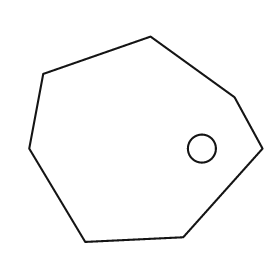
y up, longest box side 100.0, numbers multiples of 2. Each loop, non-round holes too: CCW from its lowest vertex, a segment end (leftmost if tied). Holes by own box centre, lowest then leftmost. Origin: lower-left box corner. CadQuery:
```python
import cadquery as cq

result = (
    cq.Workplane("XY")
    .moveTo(24.0, 0.0)
    .lineTo(66.0, 2.0)
    .lineTo(100.0, 40.0)
    .lineTo(88.0, 62.0)
    .lineTo(52.0, 88.0)
    .lineTo(6.0, 72.0)
    .lineTo(0.0, 40.0)
    .close()
    .moveTo(74.0, 40.0)
    .circle(6.0)
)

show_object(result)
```